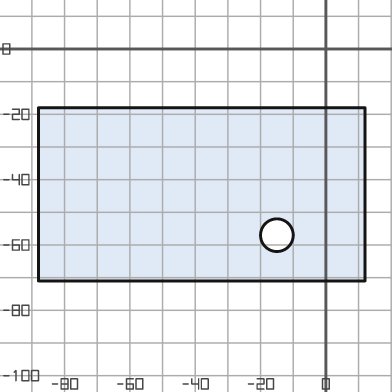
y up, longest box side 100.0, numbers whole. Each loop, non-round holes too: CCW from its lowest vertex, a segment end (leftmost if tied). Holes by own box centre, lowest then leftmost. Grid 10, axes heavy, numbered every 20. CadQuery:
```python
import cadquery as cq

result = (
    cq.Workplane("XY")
    .moveTo(-88.0, -71.0)
    .lineTo(12.0, -71.0)
    .lineTo(12.0, -18.0)
    .lineTo(-88.0, -18.0)
    .close()
    .moveTo(-15.0, -57.0)
    .circle(5.0)
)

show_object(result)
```